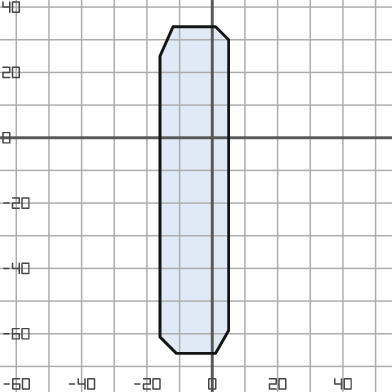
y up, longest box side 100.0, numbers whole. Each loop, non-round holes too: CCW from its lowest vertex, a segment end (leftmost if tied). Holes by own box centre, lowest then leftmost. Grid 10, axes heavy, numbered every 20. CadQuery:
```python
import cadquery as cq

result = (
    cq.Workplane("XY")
    .moveTo(-11.0, -66.0)
    .lineTo(1.0, -66.0)
    .lineTo(5.0, -59.0)
    .lineTo(5.0, 30.0)
    .lineTo(1.0, 34.0)
    .lineTo(-12.0, 34.0)
    .lineTo(-16.0, 25.0)
    .lineTo(-16.0, -61.0)
    .close()
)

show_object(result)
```